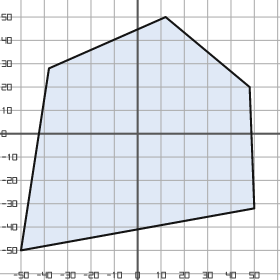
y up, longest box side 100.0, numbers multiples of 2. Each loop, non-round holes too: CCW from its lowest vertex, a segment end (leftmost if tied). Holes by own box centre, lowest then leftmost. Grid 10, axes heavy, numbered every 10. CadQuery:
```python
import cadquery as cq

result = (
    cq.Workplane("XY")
    .moveTo(-50.0, -50.0)
    .lineTo(50.0, -32.0)
    .lineTo(48.0, 20.0)
    .lineTo(12.0, 50.0)
    .lineTo(-38.0, 28.0)
    .close()
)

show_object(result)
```